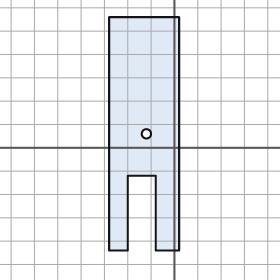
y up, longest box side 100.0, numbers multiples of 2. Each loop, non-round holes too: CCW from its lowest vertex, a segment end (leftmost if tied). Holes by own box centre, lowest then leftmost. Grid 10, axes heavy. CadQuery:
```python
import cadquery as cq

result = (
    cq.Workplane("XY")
    .moveTo(-28.0, -44.0)
    .lineTo(-20.0, -44.0)
    .lineTo(-20.0, -12.0)
    .lineTo(-8.0, -12.0)
    .lineTo(-8.0, -44.0)
    .lineTo(2.0, -44.0)
    .lineTo(2.0, 56.0)
    .lineTo(-28.0, 56.0)
    .close()
    .moveTo(-12.0, 6.0)
    .circle(2.0)
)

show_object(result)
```